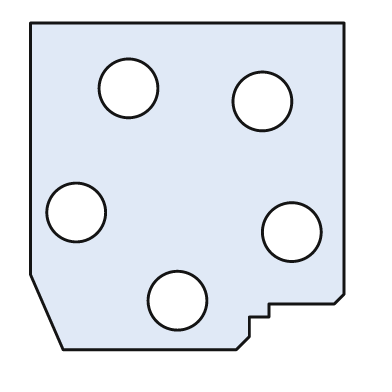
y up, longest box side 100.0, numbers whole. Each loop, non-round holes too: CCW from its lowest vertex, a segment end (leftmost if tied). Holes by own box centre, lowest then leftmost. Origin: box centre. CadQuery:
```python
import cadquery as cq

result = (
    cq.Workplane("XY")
    .moveTo(-38.0, -50.0)
    .lineTo(15.0, -50.0)
    .lineTo(19.0, -46.0)
    .lineTo(19.0, -40.0)
    .lineTo(25.0, -40.0)
    .lineTo(25.0, -36.0)
    .lineTo(45.0, -36.0)
    .lineTo(48.0, -33.0)
    .lineTo(48.0, 50.0)
    .lineTo(-48.0, 50.0)
    .lineTo(-48.0, -27.0)
    .close()
    .moveTo(-3.0, -35.0)
    .circle(9.0)
    .moveTo(32.0, -14.0)
    .circle(9.0)
    .moveTo(-34.0, -8.0)
    .circle(9.0)
    .moveTo(23.0, 26.0)
    .circle(9.0)
    .moveTo(-18.0, 30.0)
    .circle(9.0)
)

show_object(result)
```